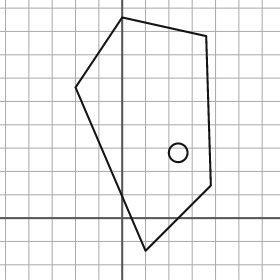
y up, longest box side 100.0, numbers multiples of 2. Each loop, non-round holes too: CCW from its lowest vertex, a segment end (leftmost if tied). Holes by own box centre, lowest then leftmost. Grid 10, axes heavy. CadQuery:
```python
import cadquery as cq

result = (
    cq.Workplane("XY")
    .moveTo(10.0, -14.0)
    .lineTo(38.0, 14.0)
    .lineTo(36.0, 78.0)
    .lineTo(0.0, 86.0)
    .lineTo(-20.0, 56.0)
    .close()
    .moveTo(24.0, 28.0)
    .circle(4.0)
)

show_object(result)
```